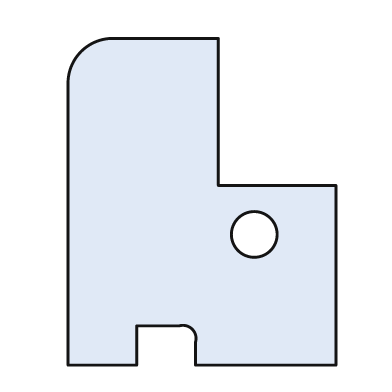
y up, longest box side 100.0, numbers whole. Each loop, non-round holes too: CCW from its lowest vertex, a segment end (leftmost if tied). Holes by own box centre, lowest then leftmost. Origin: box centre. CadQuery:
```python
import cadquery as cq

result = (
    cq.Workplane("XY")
    .moveTo(-41.0, -50.0)
    .lineTo(-20.0, -50.0)
    .lineTo(-20.0, -38.0)
    .lineTo(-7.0, -38.0)
    .threePointArc((-3.0, -39.0), (-2.0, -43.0))
    .lineTo(-2.0, -50.0)
    .lineTo(41.0, -50.0)
    .lineTo(41.0, 5.0)
    .lineTo(5.0, 5.0)
    .lineTo(5.0, 50.0)
    .lineTo(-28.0, 50.0)
    .threePointArc((-37.0, 46.0), (-41.0, 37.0))
    .close()
    .moveTo(16.0, -10.0)
    .circle(7.0)
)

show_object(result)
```